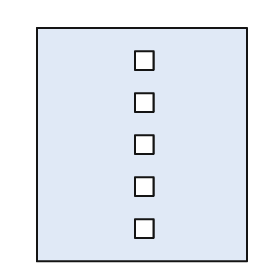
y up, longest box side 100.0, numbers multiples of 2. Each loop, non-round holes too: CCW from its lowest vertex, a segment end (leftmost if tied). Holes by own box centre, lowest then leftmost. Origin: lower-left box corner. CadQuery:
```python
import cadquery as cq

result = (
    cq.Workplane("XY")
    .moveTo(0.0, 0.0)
    .lineTo(90.0, 0.0)
    .lineTo(90.0, 100.0)
    .lineTo(0.0, 100.0)
    .close()
    .moveTo(42.0, 10.0)
    .lineTo(50.0, 10.0)
    .lineTo(50.0, 18.0)
    .lineTo(42.0, 18.0)
    .close()
    .moveTo(42.0, 28.0)
    .lineTo(50.0, 28.0)
    .lineTo(50.0, 36.0)
    .lineTo(42.0, 36.0)
    .close()
    .moveTo(42.0, 46.0)
    .lineTo(50.0, 46.0)
    .lineTo(50.0, 54.0)
    .lineTo(42.0, 54.0)
    .close()
    .moveTo(42.0, 64.0)
    .lineTo(50.0, 64.0)
    .lineTo(50.0, 72.0)
    .lineTo(42.0, 72.0)
    .close()
    .moveTo(42.0, 82.0)
    .lineTo(50.0, 82.0)
    .lineTo(50.0, 90.0)
    .lineTo(42.0, 90.0)
    .close()
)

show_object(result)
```